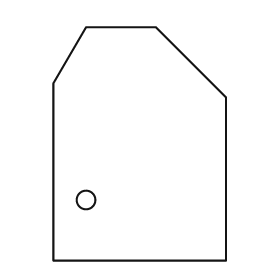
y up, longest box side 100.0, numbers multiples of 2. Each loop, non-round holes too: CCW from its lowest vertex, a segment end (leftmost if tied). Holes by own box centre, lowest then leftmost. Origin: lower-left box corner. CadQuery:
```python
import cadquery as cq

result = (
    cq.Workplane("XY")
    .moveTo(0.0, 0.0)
    .lineTo(74.0, 0.0)
    .lineTo(74.0, 70.0)
    .lineTo(44.0, 100.0)
    .lineTo(14.0, 100.0)
    .lineTo(0.0, 76.0)
    .close()
    .moveTo(14.0, 26.0)
    .circle(4.0)
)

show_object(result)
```